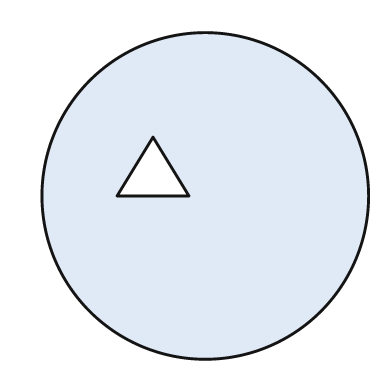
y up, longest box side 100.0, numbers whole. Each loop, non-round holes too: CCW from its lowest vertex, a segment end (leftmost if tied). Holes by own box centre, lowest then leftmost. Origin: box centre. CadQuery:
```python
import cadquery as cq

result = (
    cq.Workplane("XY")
    .moveTo(0.0, 0.0)
    .circle(50.0)
    .moveTo(-27.0, 0.0)
    .lineTo(-5.0, 0.0)
    .lineTo(-16.0, 18.0)
    .close()
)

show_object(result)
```